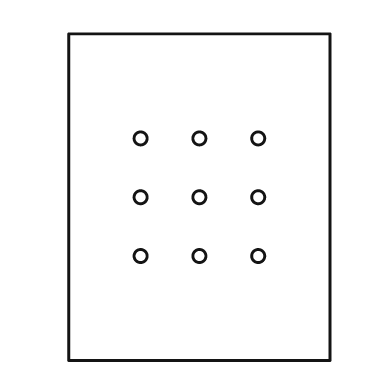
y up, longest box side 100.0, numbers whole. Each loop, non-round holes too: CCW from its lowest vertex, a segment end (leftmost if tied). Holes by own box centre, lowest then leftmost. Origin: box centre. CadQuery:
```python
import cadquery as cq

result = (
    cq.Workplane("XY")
    .moveTo(-40.0, -50.0)
    .lineTo(40.0, -50.0)
    .lineTo(40.0, 50.0)
    .lineTo(-40.0, 50.0)
    .close()
    .moveTo(-18.0, -18.0)
    .circle(2.0)
    .moveTo(0.0, -18.0)
    .circle(2.0)
    .moveTo(18.0, -18.0)
    .circle(2.0)
    .moveTo(-18.0, 0.0)
    .circle(2.0)
    .moveTo(0.0, 0.0)
    .circle(2.0)
    .moveTo(18.0, 0.0)
    .circle(2.0)
    .moveTo(-18.0, 18.0)
    .circle(2.0)
    .moveTo(0.0, 18.0)
    .circle(2.0)
    .moveTo(18.0, 18.0)
    .circle(2.0)
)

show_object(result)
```